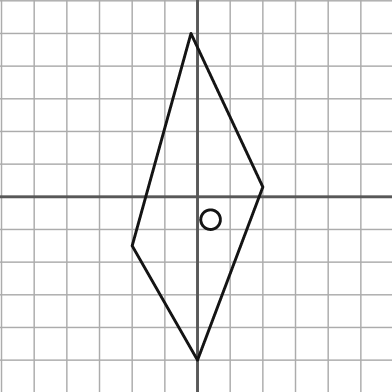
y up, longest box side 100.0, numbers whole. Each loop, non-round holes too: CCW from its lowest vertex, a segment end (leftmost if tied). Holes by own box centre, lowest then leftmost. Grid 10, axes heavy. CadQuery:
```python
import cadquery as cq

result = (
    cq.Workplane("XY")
    .moveTo(0.0, -50.0)
    .lineTo(20.0, 3.0)
    .lineTo(-2.0, 50.0)
    .lineTo(-20.0, -15.0)
    .close()
    .moveTo(4.0, -7.0)
    .circle(3.0)
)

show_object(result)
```